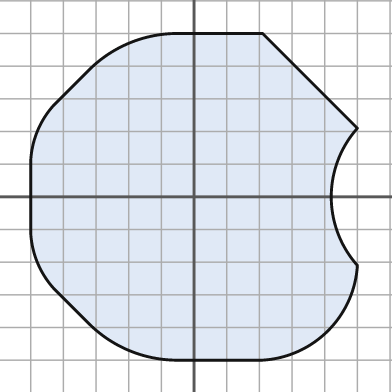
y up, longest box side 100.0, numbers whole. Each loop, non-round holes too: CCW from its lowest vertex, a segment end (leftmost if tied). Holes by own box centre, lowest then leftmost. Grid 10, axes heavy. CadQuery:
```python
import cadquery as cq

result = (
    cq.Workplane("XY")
    .moveTo(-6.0, -50.0)
    .lineTo(21.0, -50.0)
    .threePointArc((41.0, -41.0), (50.0, -21.0))
    .threePointArc((42.0, 0.0), (50.0, 21.0))
    .lineTo(21.0, 50.0)
    .lineTo(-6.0, 50.0)
    .threePointArc((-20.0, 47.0), (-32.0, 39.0))
    .lineTo(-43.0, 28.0)
    .threePointArc((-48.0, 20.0), (-50.0, 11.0))
    .lineTo(-50.0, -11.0)
    .threePointArc((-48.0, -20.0), (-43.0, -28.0))
    .lineTo(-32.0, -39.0)
    .threePointArc((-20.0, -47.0), (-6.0, -50.0))
    .close()
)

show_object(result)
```